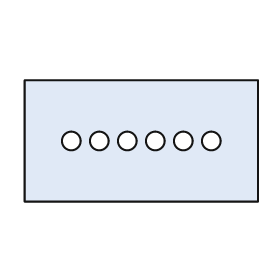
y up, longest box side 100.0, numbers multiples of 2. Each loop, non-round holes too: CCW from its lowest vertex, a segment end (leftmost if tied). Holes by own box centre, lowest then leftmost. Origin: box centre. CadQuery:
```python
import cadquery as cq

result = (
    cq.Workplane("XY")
    .moveTo(-50.0, -26.0)
    .lineTo(50.0, -26.0)
    .lineTo(50.0, 26.0)
    .lineTo(-50.0, 26.0)
    .close()
    .moveTo(-30.0, 0.0)
    .circle(4.0)
    .moveTo(-18.0, 0.0)
    .circle(4.0)
    .moveTo(-6.0, 0.0)
    .circle(4.0)
    .moveTo(6.0, 0.0)
    .circle(4.0)
    .moveTo(18.0, 0.0)
    .circle(4.0)
    .moveTo(30.0, 0.0)
    .circle(4.0)
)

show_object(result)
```